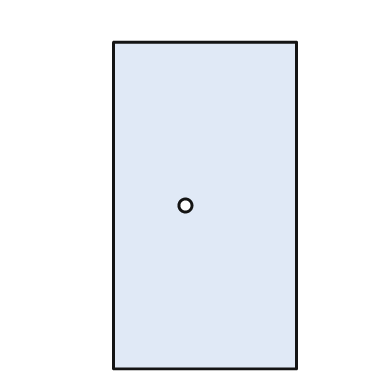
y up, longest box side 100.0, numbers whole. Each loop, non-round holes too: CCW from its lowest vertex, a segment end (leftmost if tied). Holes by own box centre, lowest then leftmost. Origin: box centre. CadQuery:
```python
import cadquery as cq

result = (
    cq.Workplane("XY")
    .moveTo(-28.0, -50.0)
    .lineTo(28.0, -50.0)
    .lineTo(28.0, 50.0)
    .lineTo(-28.0, 50.0)
    .close()
    .moveTo(-6.0, 0.0)
    .circle(2.0)
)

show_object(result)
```